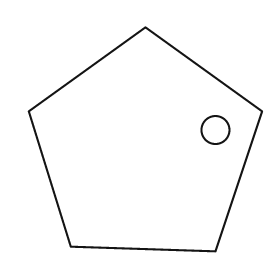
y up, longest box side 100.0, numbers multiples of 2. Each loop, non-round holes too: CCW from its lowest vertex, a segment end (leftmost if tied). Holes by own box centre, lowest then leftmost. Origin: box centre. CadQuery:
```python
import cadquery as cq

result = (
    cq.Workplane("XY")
    .moveTo(30.0, -48.0)
    .lineTo(50.0, 12.0)
    .lineTo(0.0, 48.0)
    .lineTo(-50.0, 12.0)
    .lineTo(-32.0, -46.0)
    .close()
    .moveTo(30.0, 4.0)
    .circle(6.0)
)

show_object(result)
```